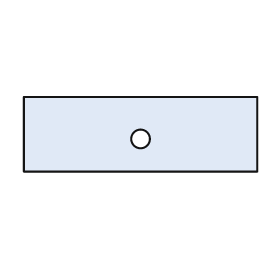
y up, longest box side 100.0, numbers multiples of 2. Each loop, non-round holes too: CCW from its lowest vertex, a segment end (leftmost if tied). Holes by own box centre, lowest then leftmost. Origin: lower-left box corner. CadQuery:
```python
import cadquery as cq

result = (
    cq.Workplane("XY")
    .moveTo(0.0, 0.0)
    .lineTo(100.0, 0.0)
    .lineTo(100.0, 32.0)
    .lineTo(0.0, 32.0)
    .close()
    .moveTo(50.0, 14.0)
    .circle(4.0)
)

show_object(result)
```